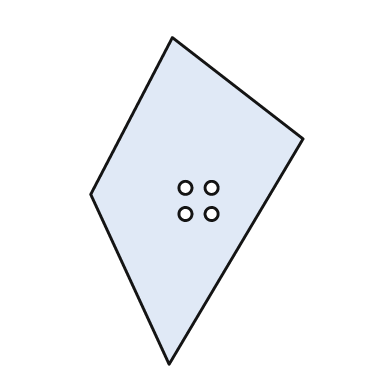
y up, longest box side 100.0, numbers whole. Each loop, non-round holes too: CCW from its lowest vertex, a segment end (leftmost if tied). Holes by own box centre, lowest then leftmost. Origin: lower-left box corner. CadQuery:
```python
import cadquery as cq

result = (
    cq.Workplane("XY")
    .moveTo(24.0, 0.0)
    .lineTo(65.0, 69.0)
    .lineTo(25.0, 100.0)
    .lineTo(0.0, 52.0)
    .close()
    .moveTo(29.0, 46.0)
    .circle(2.0)
    .moveTo(37.0, 46.0)
    .circle(2.0)
    .moveTo(29.0, 54.0)
    .circle(2.0)
    .moveTo(37.0, 54.0)
    .circle(2.0)
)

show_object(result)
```